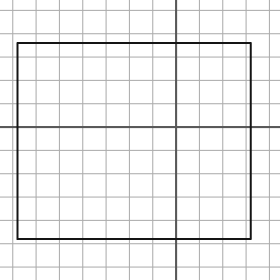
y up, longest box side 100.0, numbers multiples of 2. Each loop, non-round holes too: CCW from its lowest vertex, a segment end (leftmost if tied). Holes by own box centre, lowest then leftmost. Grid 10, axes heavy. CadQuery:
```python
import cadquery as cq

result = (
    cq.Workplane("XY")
    .moveTo(-68.0, -48.0)
    .lineTo(32.0, -48.0)
    .lineTo(32.0, 36.0)
    .lineTo(-68.0, 36.0)
    .close()
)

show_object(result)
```